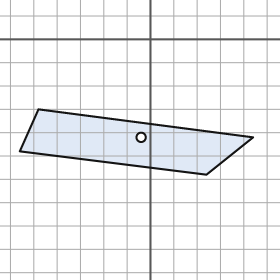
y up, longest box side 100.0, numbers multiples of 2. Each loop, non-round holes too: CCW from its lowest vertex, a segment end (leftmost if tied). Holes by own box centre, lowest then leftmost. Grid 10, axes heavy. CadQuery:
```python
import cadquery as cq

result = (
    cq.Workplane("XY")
    .moveTo(24.0, -58.0)
    .lineTo(44.0, -42.0)
    .lineTo(-48.0, -30.0)
    .lineTo(-56.0, -48.0)
    .close()
    .moveTo(-4.0, -42.0)
    .circle(2.0)
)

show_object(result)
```